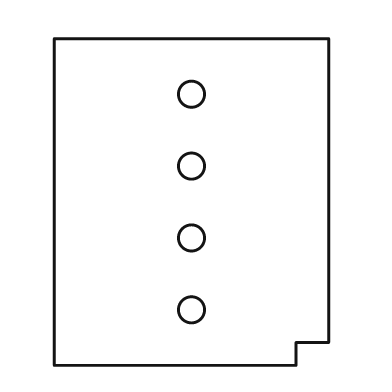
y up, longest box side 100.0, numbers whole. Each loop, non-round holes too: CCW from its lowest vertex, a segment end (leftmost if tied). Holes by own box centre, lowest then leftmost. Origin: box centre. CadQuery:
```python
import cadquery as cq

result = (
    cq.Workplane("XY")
    .moveTo(-42.0, -50.0)
    .lineTo(32.0, -50.0)
    .lineTo(32.0, -43.0)
    .lineTo(42.0, -43.0)
    .lineTo(42.0, 50.0)
    .lineTo(-42.0, 50.0)
    .close()
    .moveTo(0.0, -33.0)
    .circle(4.0)
    .moveTo(0.0, -11.0)
    .circle(4.0)
    .moveTo(0.0, 11.0)
    .circle(4.0)
    .moveTo(0.0, 33.0)
    .circle(4.0)
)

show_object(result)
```